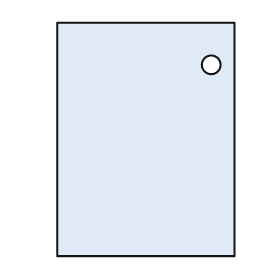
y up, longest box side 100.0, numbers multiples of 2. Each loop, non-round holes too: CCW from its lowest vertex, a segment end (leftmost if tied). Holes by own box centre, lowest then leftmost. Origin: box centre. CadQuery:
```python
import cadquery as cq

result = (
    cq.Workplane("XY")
    .moveTo(-38.0, -50.0)
    .lineTo(38.0, -50.0)
    .lineTo(38.0, 50.0)
    .lineTo(-38.0, 50.0)
    .close()
    .moveTo(28.0, 32.0)
    .circle(4.0)
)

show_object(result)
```